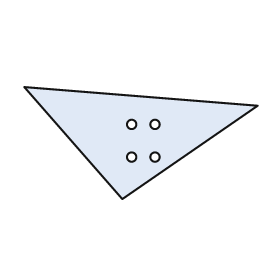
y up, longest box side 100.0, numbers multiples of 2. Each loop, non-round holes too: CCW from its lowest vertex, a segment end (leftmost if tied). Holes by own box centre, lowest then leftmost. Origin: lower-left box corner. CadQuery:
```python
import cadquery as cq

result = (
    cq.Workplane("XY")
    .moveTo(42.0, 0.0)
    .lineTo(100.0, 40.0)
    .lineTo(0.0, 48.0)
    .close()
    .moveTo(46.0, 18.0)
    .circle(2.0)
    .moveTo(56.0, 18.0)
    .circle(2.0)
    .moveTo(46.0, 32.0)
    .circle(2.0)
    .moveTo(56.0, 32.0)
    .circle(2.0)
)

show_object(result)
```